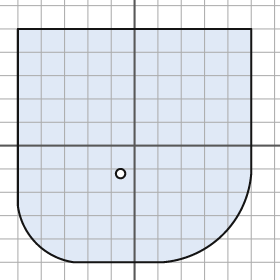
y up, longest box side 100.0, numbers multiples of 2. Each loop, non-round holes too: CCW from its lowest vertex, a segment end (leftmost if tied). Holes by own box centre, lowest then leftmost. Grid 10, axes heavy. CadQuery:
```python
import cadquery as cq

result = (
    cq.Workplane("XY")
    .moveTo(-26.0, -50.0)
    .lineTo(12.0, -50.0)
    .threePointArc((38.0, -38.0), (50.0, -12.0))
    .lineTo(50.0, 50.0)
    .lineTo(-50.0, 50.0)
    .lineTo(-50.0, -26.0)
    .threePointArc((-42.0, -42.0), (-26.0, -50.0))
    .close()
    .moveTo(-6.0, -12.0)
    .circle(2.0)
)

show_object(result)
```